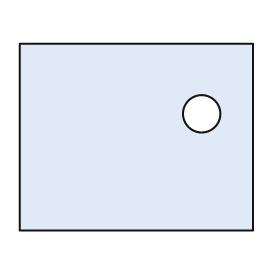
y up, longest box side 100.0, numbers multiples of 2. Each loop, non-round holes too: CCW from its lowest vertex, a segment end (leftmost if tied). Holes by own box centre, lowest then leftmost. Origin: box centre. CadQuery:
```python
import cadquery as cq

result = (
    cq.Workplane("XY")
    .moveTo(-50.0, -40.0)
    .lineTo(50.0, -40.0)
    .lineTo(50.0, 40.0)
    .lineTo(-50.0, 40.0)
    .close()
    .moveTo(28.0, 10.0)
    .circle(8.0)
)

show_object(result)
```